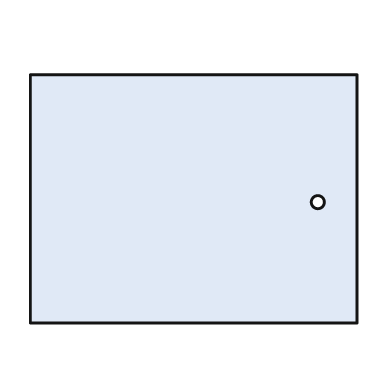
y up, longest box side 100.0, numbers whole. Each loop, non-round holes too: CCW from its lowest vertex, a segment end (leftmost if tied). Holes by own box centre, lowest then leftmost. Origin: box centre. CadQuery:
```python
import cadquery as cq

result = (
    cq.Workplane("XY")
    .moveTo(-50.0, -38.0)
    .lineTo(50.0, -38.0)
    .lineTo(50.0, 38.0)
    .lineTo(-50.0, 38.0)
    .close()
    .moveTo(38.0, -1.0)
    .circle(2.0)
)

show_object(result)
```